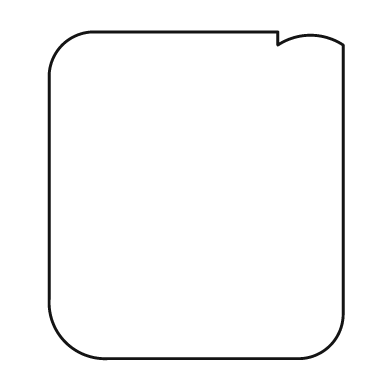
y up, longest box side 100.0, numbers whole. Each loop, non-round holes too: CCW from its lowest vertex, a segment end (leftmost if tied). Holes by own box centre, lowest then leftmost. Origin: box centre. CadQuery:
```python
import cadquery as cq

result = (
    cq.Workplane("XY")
    .moveTo(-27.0, -50.0)
    .lineTo(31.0, -50.0)
    .threePointArc((41.0, -46.0), (45.0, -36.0))
    .lineTo(45.0, 46.0)
    .threePointArc((35.0, 49.0), (25.0, 46.0))
    .lineTo(25.0, 50.0)
    .lineTo(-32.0, 50.0)
    .threePointArc((-41.0, 46.0), (-45.0, 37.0))
    .lineTo(-45.0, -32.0)
    .threePointArc((-40.0, -45.0), (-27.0, -50.0))
    .close()
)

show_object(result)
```